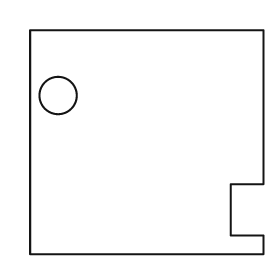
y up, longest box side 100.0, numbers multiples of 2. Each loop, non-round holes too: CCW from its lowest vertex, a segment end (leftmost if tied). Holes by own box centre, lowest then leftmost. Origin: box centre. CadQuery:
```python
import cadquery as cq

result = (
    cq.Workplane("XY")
    .moveTo(-50.0, -48.0)
    .lineTo(50.0, -48.0)
    .lineTo(50.0, -40.0)
    .lineTo(36.0, -40.0)
    .lineTo(36.0, -18.0)
    .lineTo(50.0, -18.0)
    .lineTo(50.0, 48.0)
    .lineTo(-50.0, 48.0)
    .close()
    .moveTo(-38.0, 20.0)
    .circle(8.0)
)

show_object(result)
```